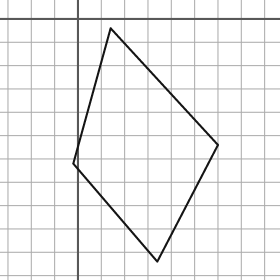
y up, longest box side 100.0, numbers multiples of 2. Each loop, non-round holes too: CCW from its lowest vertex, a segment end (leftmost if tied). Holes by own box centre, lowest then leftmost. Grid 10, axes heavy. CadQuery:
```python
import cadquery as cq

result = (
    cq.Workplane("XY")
    .moveTo(34.0, -104.0)
    .lineTo(60.0, -54.0)
    .lineTo(14.0, -4.0)
    .lineTo(-2.0, -62.0)
    .close()
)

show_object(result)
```